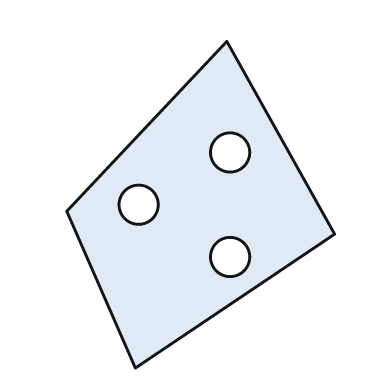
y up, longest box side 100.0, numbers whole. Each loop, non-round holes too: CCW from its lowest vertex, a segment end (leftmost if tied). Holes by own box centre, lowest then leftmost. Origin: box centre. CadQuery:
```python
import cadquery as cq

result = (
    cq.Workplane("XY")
    .moveTo(-20.0, -50.0)
    .lineTo(41.0, -9.0)
    .lineTo(8.0, 50.0)
    .lineTo(-41.0, -2.0)
    .close()
    .moveTo(9.0, -16.0)
    .circle(6.0)
    .moveTo(-19.0, 0.0)
    .circle(6.0)
    .moveTo(9.0, 16.0)
    .circle(6.0)
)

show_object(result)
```